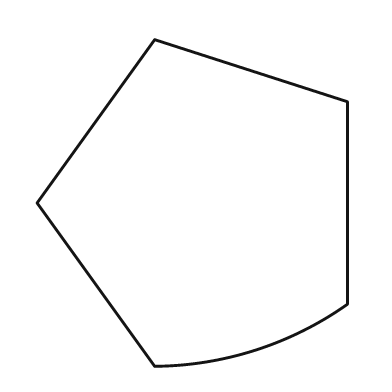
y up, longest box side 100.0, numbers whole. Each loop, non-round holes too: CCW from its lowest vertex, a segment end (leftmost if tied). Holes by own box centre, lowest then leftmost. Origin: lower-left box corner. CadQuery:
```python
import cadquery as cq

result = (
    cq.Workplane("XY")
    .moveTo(36.0, 0.0)
    .threePointArc((67.0, 5.0), (95.0, 19.0))
    .lineTo(95.0, 81.0)
    .lineTo(36.0, 100.0)
    .lineTo(0.0, 50.0)
    .close()
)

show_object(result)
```